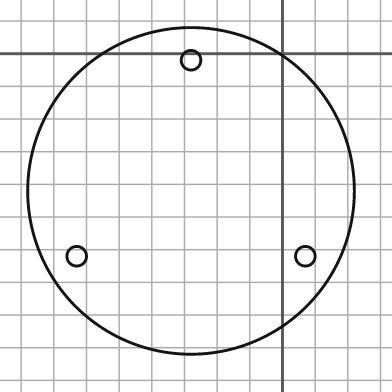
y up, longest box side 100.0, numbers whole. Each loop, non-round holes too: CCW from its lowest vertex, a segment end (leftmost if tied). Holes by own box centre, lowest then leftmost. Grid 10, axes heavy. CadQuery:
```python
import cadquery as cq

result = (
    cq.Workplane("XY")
    .moveTo(-28.0, -42.0)
    .circle(50.0)
    .moveTo(-63.0, -62.0)
    .circle(3.0)
    .moveTo(7.0, -62.0)
    .circle(3.0)
    .moveTo(-28.0, -2.0)
    .circle(3.0)
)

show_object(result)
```